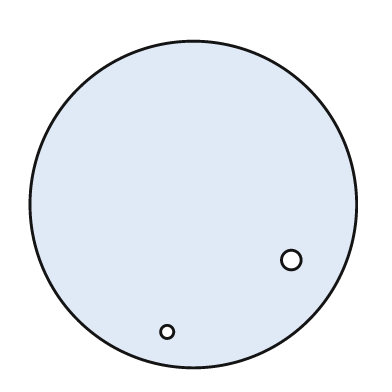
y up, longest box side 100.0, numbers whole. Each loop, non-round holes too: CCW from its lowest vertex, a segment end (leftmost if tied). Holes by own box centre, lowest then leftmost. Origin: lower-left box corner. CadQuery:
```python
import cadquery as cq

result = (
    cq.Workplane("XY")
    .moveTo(50.0, 50.0)
    .circle(50.0)
    .moveTo(42.0, 11.0)
    .circle(2.0)
    .moveTo(80.0, 33.0)
    .circle(3.0)
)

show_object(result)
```